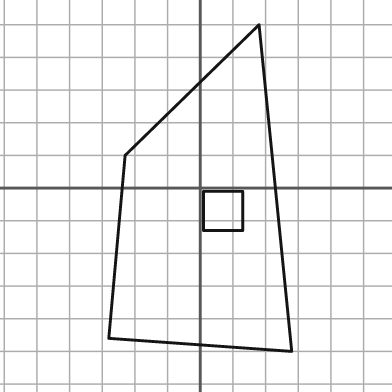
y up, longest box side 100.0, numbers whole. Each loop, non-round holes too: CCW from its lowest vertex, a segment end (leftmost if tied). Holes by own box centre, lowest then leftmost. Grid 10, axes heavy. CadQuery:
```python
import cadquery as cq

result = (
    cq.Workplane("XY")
    .moveTo(28.0, -50.0)
    .lineTo(18.0, 50.0)
    .lineTo(-23.0, 10.0)
    .lineTo(-28.0, -46.0)
    .close()
    .moveTo(1.0, -13.0)
    .lineTo(13.0, -13.0)
    .lineTo(13.0, -1.0)
    .lineTo(1.0, -1.0)
    .close()
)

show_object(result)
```